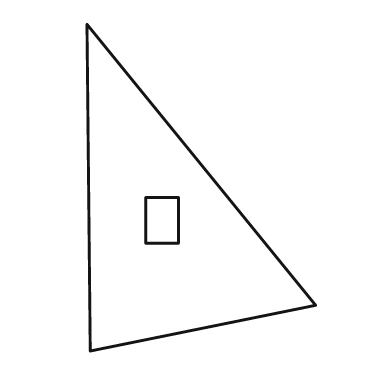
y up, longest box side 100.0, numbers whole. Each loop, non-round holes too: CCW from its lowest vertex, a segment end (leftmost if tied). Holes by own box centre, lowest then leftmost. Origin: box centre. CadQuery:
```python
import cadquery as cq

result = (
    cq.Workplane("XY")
    .moveTo(-34.0, -50.0)
    .lineTo(35.0, -36.0)
    .lineTo(-35.0, 50.0)
    .close()
    .moveTo(-17.0, -17.0)
    .lineTo(-7.0, -17.0)
    .lineTo(-7.0, -3.0)
    .lineTo(-17.0, -3.0)
    .close()
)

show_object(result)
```